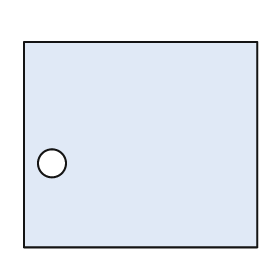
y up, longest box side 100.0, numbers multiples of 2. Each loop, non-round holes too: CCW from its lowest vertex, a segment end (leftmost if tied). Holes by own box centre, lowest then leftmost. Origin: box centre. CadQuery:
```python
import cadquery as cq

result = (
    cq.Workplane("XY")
    .moveTo(-50.0, -44.0)
    .lineTo(50.0, -44.0)
    .lineTo(50.0, 44.0)
    .lineTo(-50.0, 44.0)
    .close()
    .moveTo(-38.0, -8.0)
    .circle(6.0)
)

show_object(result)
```